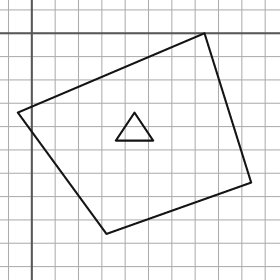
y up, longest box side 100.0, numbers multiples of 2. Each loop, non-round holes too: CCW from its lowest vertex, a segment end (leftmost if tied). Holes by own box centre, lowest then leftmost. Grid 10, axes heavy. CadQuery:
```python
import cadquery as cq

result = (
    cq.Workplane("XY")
    .moveTo(32.0, -86.0)
    .lineTo(94.0, -64.0)
    .lineTo(74.0, 0.0)
    .lineTo(-6.0, -34.0)
    .close()
    .moveTo(36.0, -46.0)
    .lineTo(52.0, -46.0)
    .lineTo(44.0, -34.0)
    .close()
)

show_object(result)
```